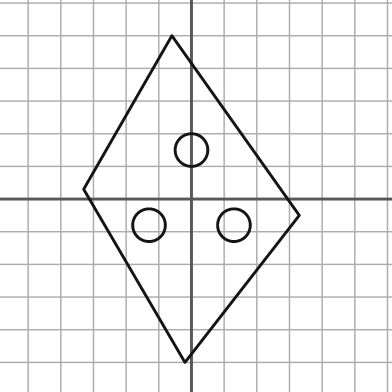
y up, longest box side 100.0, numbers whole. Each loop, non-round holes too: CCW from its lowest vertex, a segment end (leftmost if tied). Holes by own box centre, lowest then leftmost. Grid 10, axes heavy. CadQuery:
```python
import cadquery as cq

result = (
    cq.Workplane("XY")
    .moveTo(-2.0, -50.0)
    .lineTo(33.0, -5.0)
    .lineTo(-6.0, 50.0)
    .lineTo(-33.0, 3.0)
    .close()
    .moveTo(-13.0, -8.0)
    .circle(5.0)
    .moveTo(13.0, -8.0)
    .circle(5.0)
    .moveTo(0.0, 15.0)
    .circle(5.0)
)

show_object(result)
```